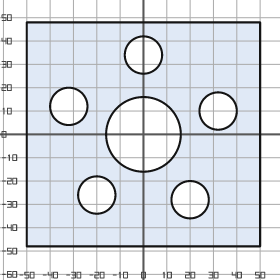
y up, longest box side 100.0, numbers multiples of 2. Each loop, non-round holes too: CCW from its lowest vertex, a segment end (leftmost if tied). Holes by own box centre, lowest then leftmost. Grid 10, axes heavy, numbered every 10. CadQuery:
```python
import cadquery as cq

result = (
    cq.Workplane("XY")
    .moveTo(-50.0, -48.0)
    .lineTo(50.0, -48.0)
    .lineTo(50.0, 48.0)
    .lineTo(-50.0, 48.0)
    .close()
    .moveTo(20.0, -28.0)
    .circle(8.0)
    .moveTo(-20.0, -26.0)
    .circle(8.0)
    .moveTo(0.0, 0.0)
    .circle(16.0)
    .moveTo(32.0, 10.0)
    .circle(8.0)
    .moveTo(-32.0, 12.0)
    .circle(8.0)
    .moveTo(0.0, 34.0)
    .circle(8.0)
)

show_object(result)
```